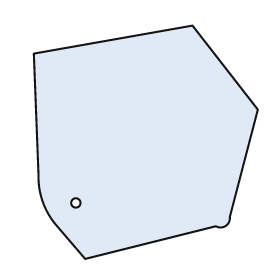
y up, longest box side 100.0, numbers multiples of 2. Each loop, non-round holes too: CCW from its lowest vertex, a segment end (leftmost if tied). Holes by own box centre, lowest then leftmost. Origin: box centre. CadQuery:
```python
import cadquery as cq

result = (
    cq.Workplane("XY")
    .moveTo(-26.0, -50.0)
    .lineTo(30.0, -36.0)
    .threePointArc((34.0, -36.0), (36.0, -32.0))
    .lineTo(48.0, 14.0)
    .lineTo(20.0, 50.0)
    .lineTo(-48.0, 38.0)
    .lineTo(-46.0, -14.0)
    .threePointArc((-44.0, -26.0), (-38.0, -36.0))
    .close()
    .moveTo(-30.0, -26.0)
    .circle(2.0)
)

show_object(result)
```